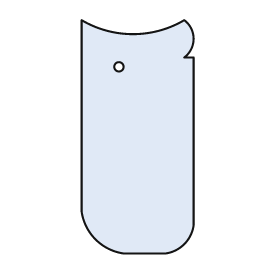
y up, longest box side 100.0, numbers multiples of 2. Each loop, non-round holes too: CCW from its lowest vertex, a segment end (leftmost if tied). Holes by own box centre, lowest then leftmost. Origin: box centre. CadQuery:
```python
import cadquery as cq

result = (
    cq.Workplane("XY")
    .moveTo(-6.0, -50.0)
    .lineTo(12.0, -50.0)
    .threePointArc((20.0, -46.0), (24.0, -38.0))
    .lineTo(24.0, 34.0)
    .lineTo(20.0, 34.0)
    .threePointArc((24.0, 42.0), (20.0, 50.0))
    .threePointArc((-2.0, 44.0), (-24.0, 50.0))
    .lineTo(-24.0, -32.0)
    .threePointArc((-18.0, -44.0), (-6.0, -50.0))
    .close()
    .moveTo(-8.0, 30.0)
    .circle(2.0)
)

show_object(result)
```